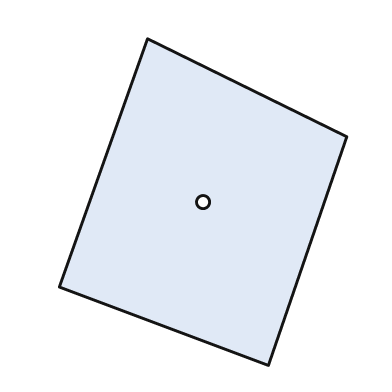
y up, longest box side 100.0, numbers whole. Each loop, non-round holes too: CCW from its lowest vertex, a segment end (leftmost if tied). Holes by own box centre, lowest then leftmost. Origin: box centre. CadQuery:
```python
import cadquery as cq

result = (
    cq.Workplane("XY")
    .moveTo(20.0, -50.0)
    .lineTo(44.0, 20.0)
    .lineTo(-17.0, 50.0)
    .lineTo(-44.0, -26.0)
    .close()
    .moveTo(0.0, 0.0)
    .circle(2.0)
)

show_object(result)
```